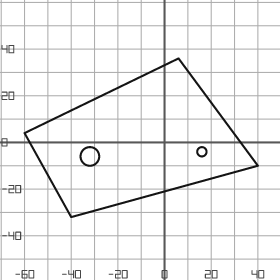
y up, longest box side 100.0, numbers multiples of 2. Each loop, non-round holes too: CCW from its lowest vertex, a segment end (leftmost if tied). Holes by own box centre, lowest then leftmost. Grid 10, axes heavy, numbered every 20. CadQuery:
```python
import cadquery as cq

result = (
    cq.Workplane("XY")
    .moveTo(-40.0, -32.0)
    .lineTo(40.0, -10.0)
    .lineTo(6.0, 36.0)
    .lineTo(-60.0, 4.0)
    .close()
    .moveTo(-32.0, -6.0)
    .circle(4.0)
    .moveTo(16.0, -4.0)
    .circle(2.0)
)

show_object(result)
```